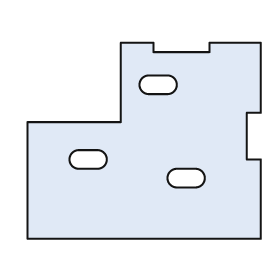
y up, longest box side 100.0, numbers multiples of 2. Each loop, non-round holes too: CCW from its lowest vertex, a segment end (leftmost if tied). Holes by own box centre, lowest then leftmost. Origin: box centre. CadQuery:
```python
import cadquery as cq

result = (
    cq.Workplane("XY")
    .moveTo(-50.0, -42.0)
    .lineTo(50.0, -42.0)
    .lineTo(50.0, -8.0)
    .lineTo(44.0, -8.0)
    .lineTo(44.0, 12.0)
    .lineTo(50.0, 12.0)
    .lineTo(50.0, 42.0)
    .lineTo(28.0, 42.0)
    .lineTo(28.0, 38.0)
    .lineTo(4.0, 38.0)
    .lineTo(4.0, 42.0)
    .lineTo(-10.0, 42.0)
    .lineTo(-10.0, 8.0)
    .lineTo(-50.0, 8.0)
    .close()
    .moveTo(14.0, -20.0)
    .lineTo(22.0, -20.0)
    .threePointArc((26.0, -16.0), (22.0, -12.0))
    .lineTo(14.0, -12.0)
    .threePointArc((10.0, -16.0), (14.0, -20.0))
    .close()
    .moveTo(-28.0, -12.0)
    .lineTo(-20.0, -12.0)
    .threePointArc((-16.0, -8.0), (-20.0, -4.0))
    .lineTo(-28.0, -4.0)
    .threePointArc((-32.0, -8.0), (-28.0, -12.0))
    .close()
    .moveTo(2.0, 20.0)
    .lineTo(10.0, 20.0)
    .threePointArc((14.0, 24.0), (10.0, 28.0))
    .lineTo(2.0, 28.0)
    .threePointArc((-2.0, 24.0), (2.0, 20.0))
    .close()
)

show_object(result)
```